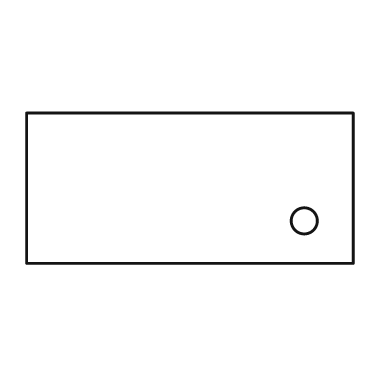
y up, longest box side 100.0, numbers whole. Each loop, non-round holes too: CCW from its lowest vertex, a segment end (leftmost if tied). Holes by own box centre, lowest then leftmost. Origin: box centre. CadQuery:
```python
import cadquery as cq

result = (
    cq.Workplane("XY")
    .moveTo(-50.0, -23.0)
    .lineTo(50.0, -23.0)
    .lineTo(50.0, 23.0)
    .lineTo(-50.0, 23.0)
    .close()
    .moveTo(35.0, -10.0)
    .circle(4.0)
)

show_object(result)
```